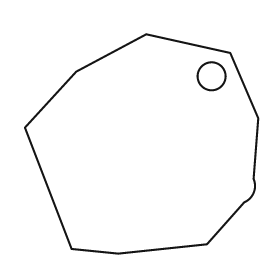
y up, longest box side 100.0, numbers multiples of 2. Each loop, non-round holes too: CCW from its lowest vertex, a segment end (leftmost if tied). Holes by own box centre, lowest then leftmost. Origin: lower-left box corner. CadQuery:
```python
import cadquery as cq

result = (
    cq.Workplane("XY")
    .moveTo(40.0, 0.0)
    .lineTo(78.0, 4.0)
    .lineTo(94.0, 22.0)
    .threePointArc((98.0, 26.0), (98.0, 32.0))
    .lineTo(100.0, 58.0)
    .lineTo(88.0, 86.0)
    .lineTo(52.0, 94.0)
    .lineTo(22.0, 78.0)
    .lineTo(0.0, 54.0)
    .lineTo(20.0, 2.0)
    .close()
    .moveTo(80.0, 76.0)
    .circle(6.0)
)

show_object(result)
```